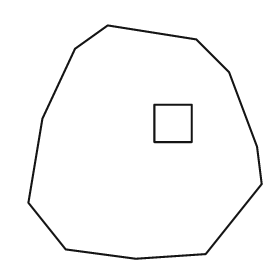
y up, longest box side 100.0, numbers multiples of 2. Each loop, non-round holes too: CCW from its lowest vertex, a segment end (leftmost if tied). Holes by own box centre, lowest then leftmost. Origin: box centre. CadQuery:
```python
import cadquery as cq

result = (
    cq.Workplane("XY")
    .moveTo(-4.0, -50.0)
    .lineTo(26.0, -48.0)
    .lineTo(50.0, -18.0)
    .lineTo(48.0, -2.0)
    .lineTo(36.0, 30.0)
    .lineTo(22.0, 44.0)
    .lineTo(-16.0, 50.0)
    .lineTo(-30.0, 40.0)
    .lineTo(-44.0, 10.0)
    .lineTo(-50.0, -26.0)
    .lineTo(-34.0, -46.0)
    .close()
    .moveTo(4.0, 0.0)
    .lineTo(20.0, 0.0)
    .lineTo(20.0, 16.0)
    .lineTo(4.0, 16.0)
    .close()
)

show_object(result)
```